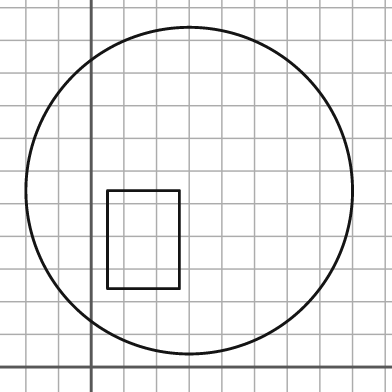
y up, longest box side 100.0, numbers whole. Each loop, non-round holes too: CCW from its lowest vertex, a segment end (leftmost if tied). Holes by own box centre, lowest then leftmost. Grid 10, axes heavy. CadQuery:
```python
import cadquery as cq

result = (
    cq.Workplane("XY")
    .moveTo(30.0, 54.0)
    .circle(50.0)
    .moveTo(5.0, 24.0)
    .lineTo(27.0, 24.0)
    .lineTo(27.0, 54.0)
    .lineTo(5.0, 54.0)
    .close()
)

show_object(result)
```